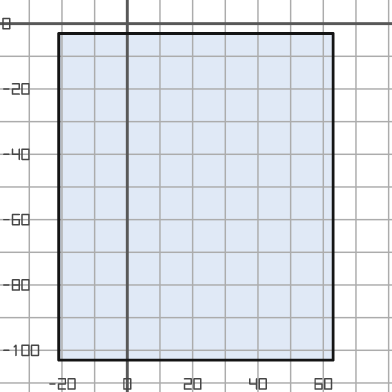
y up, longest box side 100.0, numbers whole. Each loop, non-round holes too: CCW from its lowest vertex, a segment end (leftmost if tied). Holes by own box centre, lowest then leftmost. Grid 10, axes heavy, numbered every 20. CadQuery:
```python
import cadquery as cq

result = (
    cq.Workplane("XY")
    .moveTo(-21.0, -103.0)
    .lineTo(63.0, -103.0)
    .lineTo(63.0, -3.0)
    .lineTo(-21.0, -3.0)
    .close()
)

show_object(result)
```